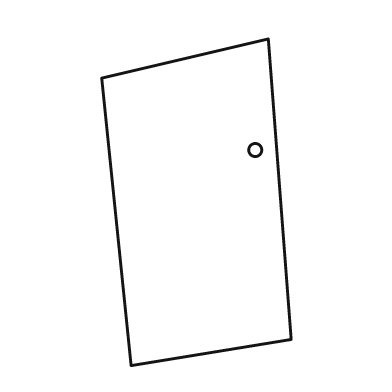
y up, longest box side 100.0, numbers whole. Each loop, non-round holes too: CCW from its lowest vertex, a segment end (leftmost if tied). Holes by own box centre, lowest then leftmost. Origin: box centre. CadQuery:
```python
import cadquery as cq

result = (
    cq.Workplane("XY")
    .moveTo(-20.0, -50.0)
    .lineTo(29.0, -42.0)
    .lineTo(22.0, 50.0)
    .lineTo(-29.0, 38.0)
    .close()
    .moveTo(18.0, 16.0)
    .circle(2.0)
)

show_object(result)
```